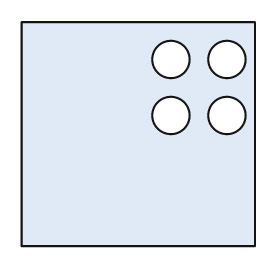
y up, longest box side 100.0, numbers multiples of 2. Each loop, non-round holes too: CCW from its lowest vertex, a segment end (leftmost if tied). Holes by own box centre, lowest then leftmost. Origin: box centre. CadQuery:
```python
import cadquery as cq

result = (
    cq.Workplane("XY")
    .moveTo(-50.0, -48.0)
    .lineTo(50.0, -48.0)
    .lineTo(50.0, 48.0)
    .lineTo(-50.0, 48.0)
    .close()
    .moveTo(14.0, 8.0)
    .circle(8.0)
    .moveTo(38.0, 8.0)
    .circle(8.0)
    .moveTo(14.0, 32.0)
    .circle(8.0)
    .moveTo(38.0, 32.0)
    .circle(8.0)
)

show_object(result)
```